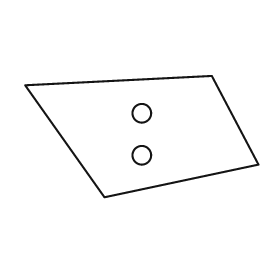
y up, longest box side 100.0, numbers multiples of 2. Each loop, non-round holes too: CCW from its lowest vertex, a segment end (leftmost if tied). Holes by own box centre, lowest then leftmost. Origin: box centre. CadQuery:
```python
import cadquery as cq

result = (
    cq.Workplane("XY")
    .moveTo(-16.0, -26.0)
    .lineTo(50.0, -12.0)
    .lineTo(30.0, 26.0)
    .lineTo(-50.0, 22.0)
    .close()
    .moveTo(0.0, -8.0)
    .circle(4.0)
    .moveTo(0.0, 10.0)
    .circle(4.0)
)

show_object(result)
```